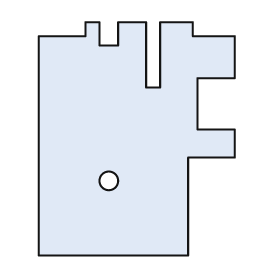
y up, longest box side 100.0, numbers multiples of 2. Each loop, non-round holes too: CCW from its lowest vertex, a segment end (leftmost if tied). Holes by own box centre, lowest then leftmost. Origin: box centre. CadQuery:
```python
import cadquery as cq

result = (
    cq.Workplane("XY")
    .moveTo(-42.0, -50.0)
    .lineTo(22.0, -50.0)
    .lineTo(22.0, -8.0)
    .lineTo(42.0, -8.0)
    .lineTo(42.0, 4.0)
    .lineTo(26.0, 4.0)
    .lineTo(26.0, 26.0)
    .lineTo(42.0, 26.0)
    .lineTo(42.0, 44.0)
    .lineTo(24.0, 44.0)
    .lineTo(24.0, 50.0)
    .lineTo(10.0, 50.0)
    .lineTo(10.0, 22.0)
    .lineTo(4.0, 22.0)
    .lineTo(4.0, 50.0)
    .lineTo(-8.0, 50.0)
    .lineTo(-8.0, 40.0)
    .lineTo(-16.0, 40.0)
    .lineTo(-16.0, 50.0)
    .lineTo(-22.0, 50.0)
    .lineTo(-22.0, 44.0)
    .lineTo(-42.0, 44.0)
    .close()
    .moveTo(-12.0, -18.0)
    .circle(4.0)
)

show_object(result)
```